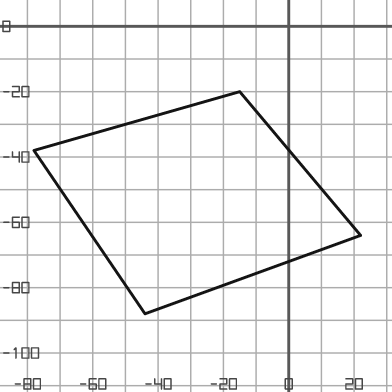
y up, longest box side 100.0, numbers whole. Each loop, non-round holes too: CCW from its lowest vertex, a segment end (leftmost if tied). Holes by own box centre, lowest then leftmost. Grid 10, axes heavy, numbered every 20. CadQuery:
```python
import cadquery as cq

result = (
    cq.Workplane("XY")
    .moveTo(-44.0, -88.0)
    .lineTo(22.0, -64.0)
    .lineTo(-15.0, -20.0)
    .lineTo(-78.0, -38.0)
    .close()
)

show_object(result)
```